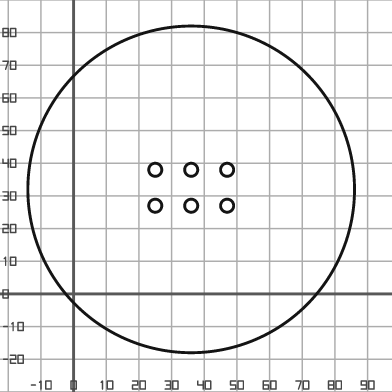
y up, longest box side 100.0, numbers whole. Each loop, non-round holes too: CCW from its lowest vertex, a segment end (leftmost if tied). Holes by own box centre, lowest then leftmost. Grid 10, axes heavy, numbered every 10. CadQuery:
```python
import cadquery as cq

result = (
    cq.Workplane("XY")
    .moveTo(36.0, 32.0)
    .circle(50.0)
    .moveTo(25.0, 27.0)
    .circle(2.0)
    .moveTo(36.0, 27.0)
    .circle(2.0)
    .moveTo(47.0, 27.0)
    .circle(2.0)
    .moveTo(25.0, 38.0)
    .circle(2.0)
    .moveTo(36.0, 38.0)
    .circle(2.0)
    .moveTo(47.0, 38.0)
    .circle(2.0)
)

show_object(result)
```